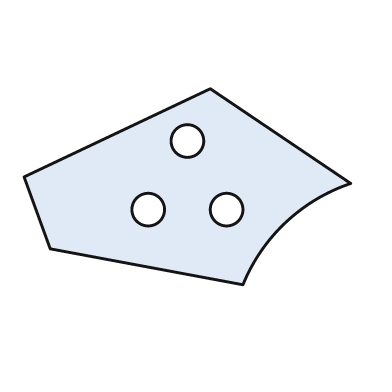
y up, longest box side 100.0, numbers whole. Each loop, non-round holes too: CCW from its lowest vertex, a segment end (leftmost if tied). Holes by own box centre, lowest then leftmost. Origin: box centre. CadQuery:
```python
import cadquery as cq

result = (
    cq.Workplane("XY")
    .moveTo(17.0, -30.0)
    .threePointArc((30.0, -11.0), (50.0, 1.0))
    .lineTo(7.0, 30.0)
    .lineTo(-50.0, 3.0)
    .lineTo(-42.0, -19.0)
    .close()
    .moveTo(-12.0, -7.0)
    .circle(5.0)
    .moveTo(12.0, -7.0)
    .circle(5.0)
    .moveTo(0.0, 14.0)
    .circle(5.0)
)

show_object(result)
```